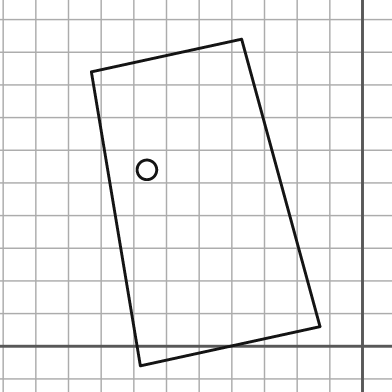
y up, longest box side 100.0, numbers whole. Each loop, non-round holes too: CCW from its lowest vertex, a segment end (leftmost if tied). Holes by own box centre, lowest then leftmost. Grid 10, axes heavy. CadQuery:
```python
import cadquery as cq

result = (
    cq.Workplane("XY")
    .moveTo(-68.0, -6.0)
    .lineTo(-13.0, 6.0)
    .lineTo(-37.0, 94.0)
    .lineTo(-83.0, 84.0)
    .close()
    .moveTo(-66.0, 54.0)
    .circle(3.0)
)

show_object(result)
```